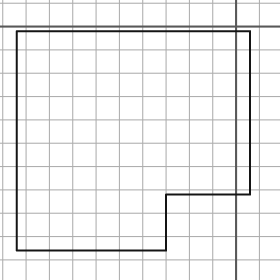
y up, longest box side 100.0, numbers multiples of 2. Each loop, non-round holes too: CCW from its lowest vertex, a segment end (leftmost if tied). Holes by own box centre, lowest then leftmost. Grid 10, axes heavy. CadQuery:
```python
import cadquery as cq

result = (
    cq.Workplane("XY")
    .moveTo(-94.0, -96.0)
    .lineTo(-30.0, -96.0)
    .lineTo(-30.0, -72.0)
    .lineTo(6.0, -72.0)
    .lineTo(6.0, -2.0)
    .lineTo(-94.0, -2.0)
    .close()
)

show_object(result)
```